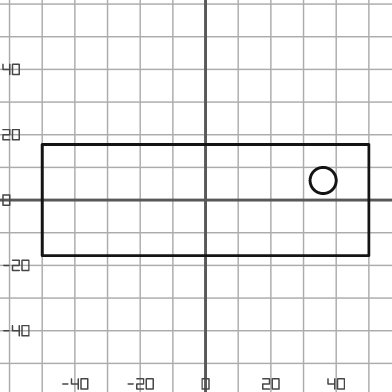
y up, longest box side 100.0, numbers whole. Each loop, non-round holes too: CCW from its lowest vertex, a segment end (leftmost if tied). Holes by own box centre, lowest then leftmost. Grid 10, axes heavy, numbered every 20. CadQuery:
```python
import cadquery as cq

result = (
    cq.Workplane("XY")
    .moveTo(-50.0, -17.0)
    .lineTo(50.0, -17.0)
    .lineTo(50.0, 17.0)
    .lineTo(-50.0, 17.0)
    .close()
    .moveTo(36.0, 6.0)
    .circle(4.0)
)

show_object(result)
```